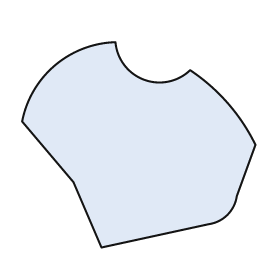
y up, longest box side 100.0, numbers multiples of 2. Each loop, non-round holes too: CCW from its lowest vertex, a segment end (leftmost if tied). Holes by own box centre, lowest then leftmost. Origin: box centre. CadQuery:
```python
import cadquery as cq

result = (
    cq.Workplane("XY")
    .moveTo(-16.0, -44.0)
    .lineTo(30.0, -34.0)
    .threePointArc((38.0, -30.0), (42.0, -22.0))
    .lineTo(50.0, 0.0)
    .threePointArc((38.0, 18.0), (22.0, 32.0))
    .threePointArc((2.0, 28.0), (-10.0, 44.0))
    .threePointArc((-36.0, 34.0), (-50.0, 10.0))
    .lineTo(-28.0, -16.0)
    .close()
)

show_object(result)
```